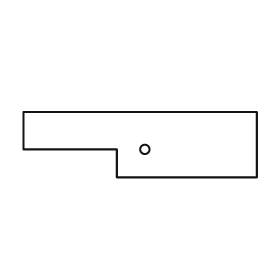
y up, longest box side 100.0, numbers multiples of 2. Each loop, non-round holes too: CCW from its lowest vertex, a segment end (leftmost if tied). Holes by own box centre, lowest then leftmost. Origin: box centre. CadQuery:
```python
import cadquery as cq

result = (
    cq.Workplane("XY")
    .moveTo(-10.0, -14.0)
    .lineTo(50.0, -14.0)
    .lineTo(50.0, 14.0)
    .lineTo(-50.0, 14.0)
    .lineTo(-50.0, -2.0)
    .lineTo(-10.0, -2.0)
    .close()
    .moveTo(2.0, -2.0)
    .circle(2.0)
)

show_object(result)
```